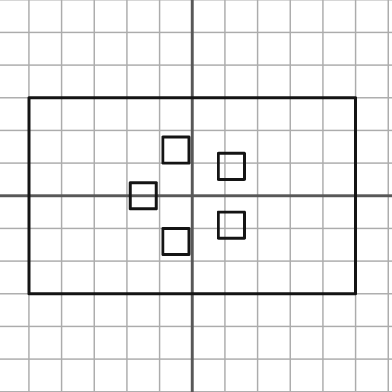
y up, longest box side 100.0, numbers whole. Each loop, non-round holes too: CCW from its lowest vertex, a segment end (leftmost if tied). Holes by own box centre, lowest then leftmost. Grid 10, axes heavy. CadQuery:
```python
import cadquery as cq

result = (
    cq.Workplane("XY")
    .moveTo(-50.0, -30.0)
    .lineTo(50.0, -30.0)
    .lineTo(50.0, 30.0)
    .lineTo(-50.0, 30.0)
    .close()
    .moveTo(-9.0, -18.0)
    .lineTo(-1.0, -18.0)
    .lineTo(-1.0, -10.0)
    .lineTo(-9.0, -10.0)
    .close()
    .moveTo(8.0, -13.0)
    .lineTo(16.0, -13.0)
    .lineTo(16.0, -5.0)
    .lineTo(8.0, -5.0)
    .close()
    .moveTo(-19.0, -4.0)
    .lineTo(-11.0, -4.0)
    .lineTo(-11.0, 4.0)
    .lineTo(-19.0, 4.0)
    .close()
    .moveTo(8.0, 5.0)
    .lineTo(16.0, 5.0)
    .lineTo(16.0, 13.0)
    .lineTo(8.0, 13.0)
    .close()
    .moveTo(-9.0, 10.0)
    .lineTo(-1.0, 10.0)
    .lineTo(-1.0, 18.0)
    .lineTo(-9.0, 18.0)
    .close()
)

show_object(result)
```